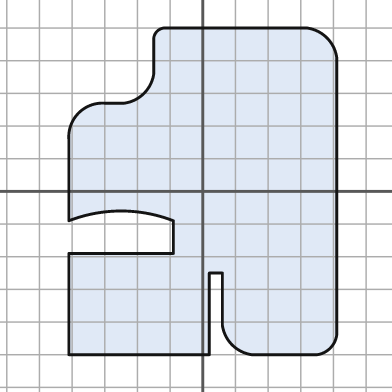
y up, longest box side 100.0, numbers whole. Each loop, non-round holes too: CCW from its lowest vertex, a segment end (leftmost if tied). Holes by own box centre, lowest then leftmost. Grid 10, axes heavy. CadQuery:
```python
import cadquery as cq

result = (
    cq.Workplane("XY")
    .moveTo(-41.0, -50.0)
    .lineTo(2.0, -50.0)
    .lineTo(2.0, -25.0)
    .lineTo(6.0, -25.0)
    .lineTo(6.0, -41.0)
    .threePointArc((9.0, -47.0), (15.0, -50.0))
    .lineTo(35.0, -50.0)
    .threePointArc((39.0, -48.0), (41.0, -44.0))
    .lineTo(41.0, 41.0)
    .threePointArc((38.0, 47.0), (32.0, 50.0))
    .lineTo(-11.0, 50.0)
    .threePointArc((-14.0, 49.0), (-15.0, 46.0))
    .lineTo(-15.0, 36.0)
    .threePointArc((-18.0, 30.0), (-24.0, 27.0))
    .lineTo(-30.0, 27.0)
    .threePointArc((-38.0, 24.0), (-41.0, 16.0))
    .lineTo(-41.0, -9.0)
    .threePointArc((-25.0, -6.0), (-9.0, -9.0))
    .lineTo(-9.0, -19.0)
    .lineTo(-41.0, -19.0)
    .close()
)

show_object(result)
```